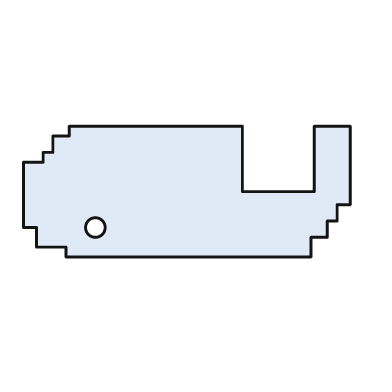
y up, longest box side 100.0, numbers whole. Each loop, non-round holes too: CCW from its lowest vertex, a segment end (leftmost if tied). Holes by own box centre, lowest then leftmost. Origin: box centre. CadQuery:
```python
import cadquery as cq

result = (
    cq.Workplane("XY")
    .moveTo(-37.0, -20.0)
    .lineTo(38.0, -20.0)
    .lineTo(38.0, -14.0)
    .lineTo(43.0, -14.0)
    .lineTo(43.0, -9.0)
    .lineTo(46.0, -9.0)
    .lineTo(46.0, -4.0)
    .lineTo(50.0, -4.0)
    .lineTo(50.0, 20.0)
    .lineTo(39.0, 20.0)
    .lineTo(39.0, 0.0)
    .lineTo(17.0, 0.0)
    .lineTo(17.0, 20.0)
    .lineTo(-36.0, 20.0)
    .lineTo(-36.0, 17.0)
    .lineTo(-41.0, 17.0)
    .lineTo(-41.0, 12.0)
    .lineTo(-44.0, 12.0)
    .lineTo(-44.0, 9.0)
    .lineTo(-50.0, 9.0)
    .lineTo(-50.0, -11.0)
    .lineTo(-46.0, -11.0)
    .lineTo(-46.0, -17.0)
    .lineTo(-37.0, -17.0)
    .close()
    .moveTo(-28.0, -11.0)
    .circle(3.0)
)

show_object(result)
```